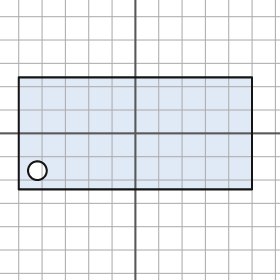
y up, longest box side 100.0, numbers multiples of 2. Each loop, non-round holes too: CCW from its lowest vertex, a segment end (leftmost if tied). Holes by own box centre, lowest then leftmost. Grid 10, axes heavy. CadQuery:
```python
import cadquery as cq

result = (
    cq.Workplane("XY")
    .moveTo(-50.0, -24.0)
    .lineTo(50.0, -24.0)
    .lineTo(50.0, 24.0)
    .lineTo(-50.0, 24.0)
    .close()
    .moveTo(-42.0, -16.0)
    .circle(4.0)
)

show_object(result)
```